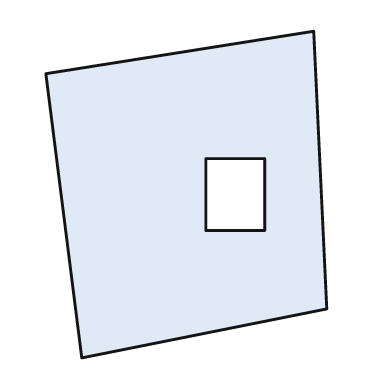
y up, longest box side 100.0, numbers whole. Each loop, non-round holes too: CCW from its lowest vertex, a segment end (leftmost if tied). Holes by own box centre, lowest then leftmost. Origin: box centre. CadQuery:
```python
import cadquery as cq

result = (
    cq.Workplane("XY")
    .moveTo(-32.0, -50.0)
    .lineTo(43.0, -35.0)
    .lineTo(39.0, 50.0)
    .lineTo(-43.0, 37.0)
    .close()
    .moveTo(6.0, -11.0)
    .lineTo(24.0, -11.0)
    .lineTo(24.0, 11.0)
    .lineTo(6.0, 11.0)
    .close()
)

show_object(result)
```